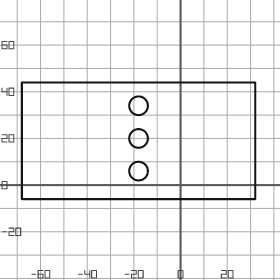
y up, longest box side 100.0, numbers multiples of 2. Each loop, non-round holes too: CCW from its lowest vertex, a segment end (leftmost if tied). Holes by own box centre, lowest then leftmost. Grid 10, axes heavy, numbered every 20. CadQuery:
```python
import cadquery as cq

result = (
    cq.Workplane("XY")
    .moveTo(-68.0, -6.0)
    .lineTo(32.0, -6.0)
    .lineTo(32.0, 44.0)
    .lineTo(-68.0, 44.0)
    .close()
    .moveTo(-18.0, 6.0)
    .circle(4.0)
    .moveTo(-18.0, 20.0)
    .circle(4.0)
    .moveTo(-18.0, 34.0)
    .circle(4.0)
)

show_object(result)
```